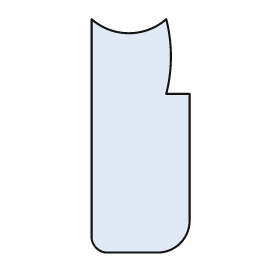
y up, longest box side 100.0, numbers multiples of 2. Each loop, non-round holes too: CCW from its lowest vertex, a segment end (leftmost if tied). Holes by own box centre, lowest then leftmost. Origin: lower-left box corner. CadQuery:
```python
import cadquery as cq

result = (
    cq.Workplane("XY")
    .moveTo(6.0, 0.0)
    .lineTo(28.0, 0.0)
    .threePointArc((38.0, 4.0), (42.0, 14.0))
    .lineTo(42.0, 68.0)
    .lineTo(32.0, 68.0)
    .threePointArc((34.0, 84.0), (32.0, 100.0))
    .threePointArc((16.0, 94.0), (0.0, 100.0))
    .lineTo(0.0, 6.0)
    .threePointArc((2.0, 2.0), (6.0, 0.0))
    .close()
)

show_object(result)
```